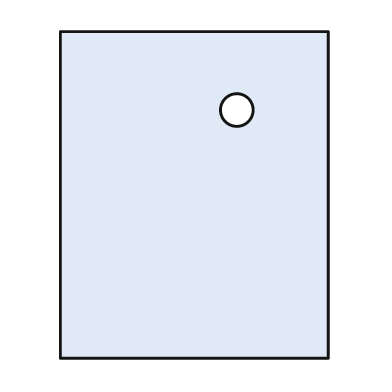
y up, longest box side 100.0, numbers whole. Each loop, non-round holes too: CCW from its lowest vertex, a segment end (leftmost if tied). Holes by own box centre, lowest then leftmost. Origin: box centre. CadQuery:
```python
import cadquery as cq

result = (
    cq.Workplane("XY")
    .moveTo(-41.0, -50.0)
    .lineTo(41.0, -50.0)
    .lineTo(41.0, 50.0)
    .lineTo(-41.0, 50.0)
    .close()
    .moveTo(13.0, 26.0)
    .circle(5.0)
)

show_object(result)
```